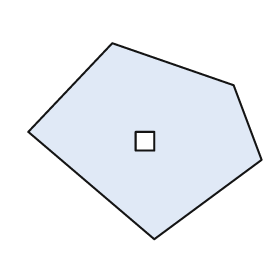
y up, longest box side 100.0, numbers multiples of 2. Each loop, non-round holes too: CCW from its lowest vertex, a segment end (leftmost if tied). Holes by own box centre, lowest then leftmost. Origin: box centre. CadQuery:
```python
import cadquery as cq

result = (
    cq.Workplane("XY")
    .moveTo(4.0, -42.0)
    .lineTo(50.0, -8.0)
    .lineTo(38.0, 24.0)
    .lineTo(-14.0, 42.0)
    .lineTo(-50.0, 4.0)
    .close()
    .moveTo(-4.0, -4.0)
    .lineTo(4.0, -4.0)
    .lineTo(4.0, 4.0)
    .lineTo(-4.0, 4.0)
    .close()
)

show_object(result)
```